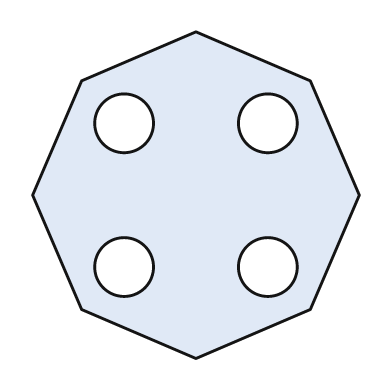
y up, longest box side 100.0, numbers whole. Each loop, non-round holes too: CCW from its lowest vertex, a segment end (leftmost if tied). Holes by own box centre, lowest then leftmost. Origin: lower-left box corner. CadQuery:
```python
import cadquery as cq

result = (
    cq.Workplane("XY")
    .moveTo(50.0, 0.0)
    .lineTo(85.0, 15.0)
    .lineTo(100.0, 50.0)
    .lineTo(85.0, 85.0)
    .lineTo(50.0, 100.0)
    .lineTo(15.0, 85.0)
    .lineTo(0.0, 50.0)
    .lineTo(15.0, 15.0)
    .close()
    .moveTo(28.0, 28.0)
    .circle(9.0)
    .moveTo(72.0, 28.0)
    .circle(9.0)
    .moveTo(28.0, 72.0)
    .circle(9.0)
    .moveTo(72.0, 72.0)
    .circle(9.0)
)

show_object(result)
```